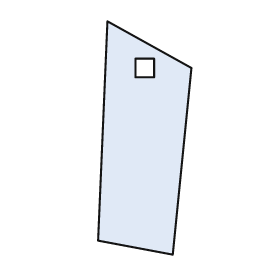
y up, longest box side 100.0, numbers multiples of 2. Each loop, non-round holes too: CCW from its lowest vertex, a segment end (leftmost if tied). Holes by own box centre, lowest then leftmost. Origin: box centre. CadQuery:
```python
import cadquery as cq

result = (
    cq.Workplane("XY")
    .moveTo(12.0, -50.0)
    .lineTo(20.0, 30.0)
    .lineTo(-16.0, 50.0)
    .lineTo(-20.0, -44.0)
    .close()
    .moveTo(-4.0, 26.0)
    .lineTo(4.0, 26.0)
    .lineTo(4.0, 34.0)
    .lineTo(-4.0, 34.0)
    .close()
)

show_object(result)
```